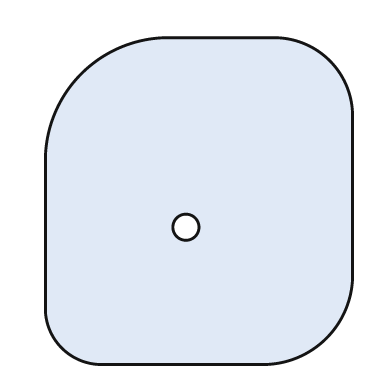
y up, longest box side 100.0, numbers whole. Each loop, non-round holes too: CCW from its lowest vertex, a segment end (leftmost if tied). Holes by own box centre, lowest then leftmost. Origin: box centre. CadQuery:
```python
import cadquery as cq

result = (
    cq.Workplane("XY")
    .moveTo(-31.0, -50.0)
    .lineTo(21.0, -50.0)
    .threePointArc((39.0, -42.0), (47.0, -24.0))
    .lineTo(47.0, 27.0)
    .threePointArc((40.0, 43.0), (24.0, 50.0))
    .lineTo(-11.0, 50.0)
    .threePointArc((-36.0, 39.0), (-47.0, 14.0))
    .lineTo(-47.0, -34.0)
    .threePointArc((-42.0, -45.0), (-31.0, -50.0))
    .close()
    .moveTo(-4.0, -8.0)
    .circle(4.0)
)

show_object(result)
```